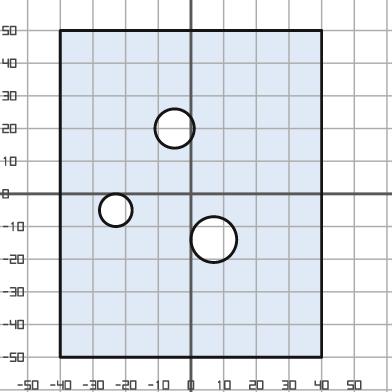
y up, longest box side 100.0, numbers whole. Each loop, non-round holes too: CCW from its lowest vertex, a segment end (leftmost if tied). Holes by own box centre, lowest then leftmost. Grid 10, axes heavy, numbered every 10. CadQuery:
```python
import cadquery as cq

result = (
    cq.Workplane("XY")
    .moveTo(-40.0, -50.0)
    .lineTo(40.0, -50.0)
    .lineTo(40.0, 50.0)
    .lineTo(-40.0, 50.0)
    .close()
    .moveTo(7.0, -14.0)
    .circle(7.0)
    .moveTo(-23.0, -5.0)
    .circle(5.0)
    .moveTo(-5.0, 20.0)
    .circle(6.0)
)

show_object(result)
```